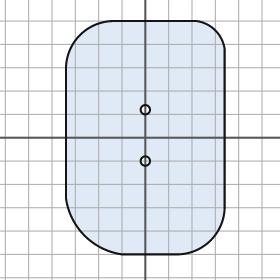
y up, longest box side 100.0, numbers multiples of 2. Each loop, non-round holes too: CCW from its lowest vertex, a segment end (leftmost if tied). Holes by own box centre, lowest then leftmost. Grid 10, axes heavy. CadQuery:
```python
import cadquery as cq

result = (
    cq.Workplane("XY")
    .moveTo(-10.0, -50.0)
    .lineTo(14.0, -50.0)
    .threePointArc((28.0, -44.0), (34.0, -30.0))
    .lineTo(34.0, 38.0)
    .threePointArc((30.0, 46.0), (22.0, 50.0))
    .lineTo(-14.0, 50.0)
    .threePointArc((-28.0, 44.0), (-34.0, 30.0))
    .lineTo(-34.0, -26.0)
    .threePointArc((-26.0, -42.0), (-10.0, -50.0))
    .close()
    .moveTo(0.0, -10.0)
    .circle(2.0)
    .moveTo(0.0, 12.0)
    .circle(2.0)
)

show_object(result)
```